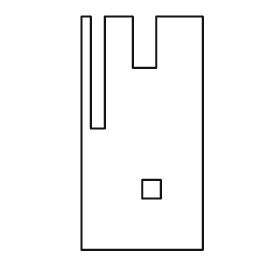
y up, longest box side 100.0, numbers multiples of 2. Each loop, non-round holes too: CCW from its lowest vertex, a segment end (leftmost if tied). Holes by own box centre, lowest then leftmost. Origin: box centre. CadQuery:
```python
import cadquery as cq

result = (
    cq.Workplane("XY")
    .moveTo(-26.0, -50.0)
    .lineTo(26.0, -50.0)
    .lineTo(26.0, 50.0)
    .lineTo(6.0, 50.0)
    .lineTo(6.0, 28.0)
    .lineTo(-4.0, 28.0)
    .lineTo(-4.0, 50.0)
    .lineTo(-16.0, 50.0)
    .lineTo(-16.0, 2.0)
    .lineTo(-22.0, 2.0)
    .lineTo(-22.0, 50.0)
    .lineTo(-26.0, 50.0)
    .close()
    .moveTo(0.0, -28.0)
    .lineTo(8.0, -28.0)
    .lineTo(8.0, -20.0)
    .lineTo(0.0, -20.0)
    .close()
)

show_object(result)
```